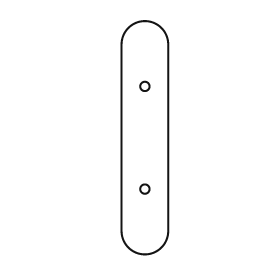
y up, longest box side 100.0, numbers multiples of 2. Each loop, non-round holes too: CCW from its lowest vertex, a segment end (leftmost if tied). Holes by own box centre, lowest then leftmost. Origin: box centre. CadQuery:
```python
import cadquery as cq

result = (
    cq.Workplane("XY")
    .moveTo(-10.0, -40.0)
    .threePointArc((0.0, -50.0), (10.0, -40.0))
    .lineTo(10.0, 40.0)
    .threePointArc((0.0, 50.0), (-10.0, 40.0))
    .close()
    .moveTo(0.0, -22.0)
    .circle(2.0)
    .moveTo(0.0, 22.0)
    .circle(2.0)
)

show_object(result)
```